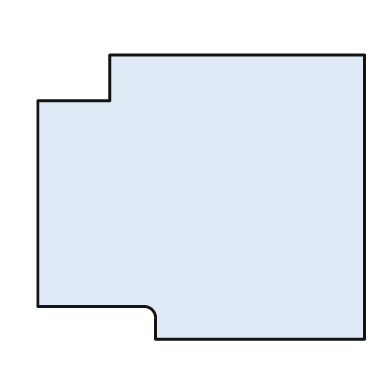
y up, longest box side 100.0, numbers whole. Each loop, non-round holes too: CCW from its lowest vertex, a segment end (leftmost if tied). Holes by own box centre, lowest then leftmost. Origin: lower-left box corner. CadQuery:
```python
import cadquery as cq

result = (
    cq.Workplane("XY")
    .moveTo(36.0, 0.0)
    .lineTo(100.0, 0.0)
    .lineTo(100.0, 87.0)
    .lineTo(22.0, 87.0)
    .lineTo(22.0, 73.0)
    .lineTo(0.0, 73.0)
    .lineTo(0.0, 10.0)
    .lineTo(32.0, 10.0)
    .threePointArc((35.0, 9.0), (36.0, 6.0))
    .close()
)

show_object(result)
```